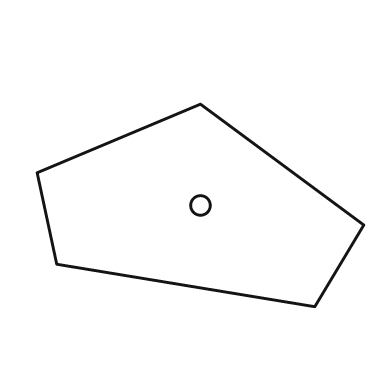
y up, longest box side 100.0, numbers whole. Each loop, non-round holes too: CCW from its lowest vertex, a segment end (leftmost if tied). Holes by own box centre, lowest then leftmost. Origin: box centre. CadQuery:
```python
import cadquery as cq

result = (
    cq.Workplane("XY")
    .moveTo(35.0, -31.0)
    .lineTo(50.0, -6.0)
    .lineTo(0.0, 31.0)
    .lineTo(-50.0, 10.0)
    .lineTo(-44.0, -18.0)
    .close()
    .moveTo(0.0, 0.0)
    .circle(3.0)
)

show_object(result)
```